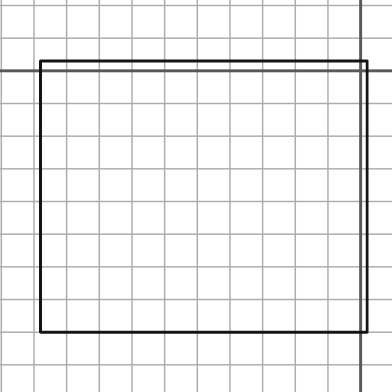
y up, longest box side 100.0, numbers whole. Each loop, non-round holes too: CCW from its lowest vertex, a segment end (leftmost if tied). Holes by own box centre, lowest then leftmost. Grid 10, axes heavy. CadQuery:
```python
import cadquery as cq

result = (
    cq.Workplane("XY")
    .moveTo(-98.0, -80.0)
    .lineTo(2.0, -80.0)
    .lineTo(2.0, 3.0)
    .lineTo(-98.0, 3.0)
    .close()
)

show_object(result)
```